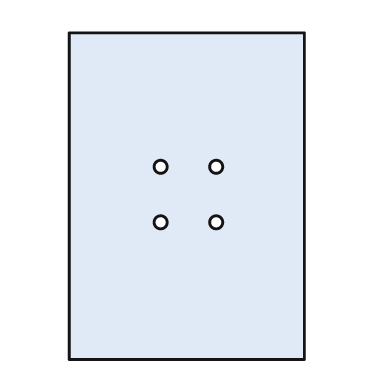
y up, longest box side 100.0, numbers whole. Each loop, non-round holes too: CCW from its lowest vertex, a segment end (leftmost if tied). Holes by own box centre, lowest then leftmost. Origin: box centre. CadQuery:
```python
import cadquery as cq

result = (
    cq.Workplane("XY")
    .moveTo(-36.0, -50.0)
    .lineTo(36.0, -50.0)
    .lineTo(36.0, 50.0)
    .lineTo(-36.0, 50.0)
    .close()
    .moveTo(-8.0, -8.0)
    .circle(2.0)
    .moveTo(9.0, -8.0)
    .circle(2.0)
    .moveTo(-8.0, 9.0)
    .circle(2.0)
    .moveTo(9.0, 9.0)
    .circle(2.0)
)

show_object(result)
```